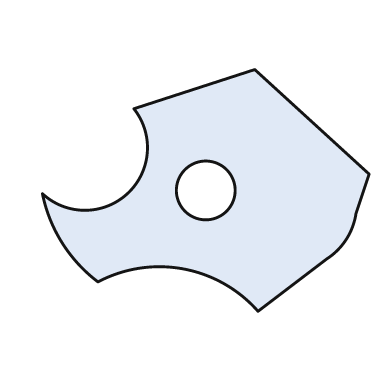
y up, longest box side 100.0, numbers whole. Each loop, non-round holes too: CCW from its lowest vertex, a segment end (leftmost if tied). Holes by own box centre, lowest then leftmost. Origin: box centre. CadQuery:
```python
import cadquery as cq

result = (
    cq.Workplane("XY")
    .moveTo(16.0, -37.0)
    .lineTo(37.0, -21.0)
    .threePointArc((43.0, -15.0), (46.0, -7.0))
    .lineTo(50.0, 5.0)
    .lineTo(15.0, 37.0)
    .lineTo(-22.0, 25.0)
    .threePointArc((-24.0, -1.0), (-50.0, -1.0))
    .threePointArc((-44.0, -16.0), (-33.0, -28.0))
    .threePointArc((-7.0, -24.0), (16.0, -37.0))
    .close()
    .moveTo(0.0, 0.0)
    .circle(9.0)
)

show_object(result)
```